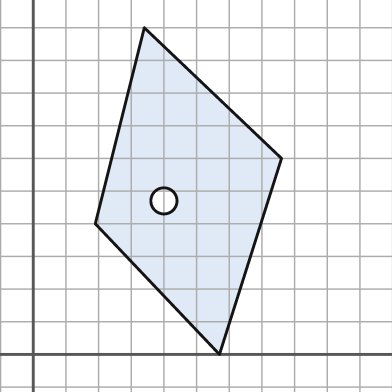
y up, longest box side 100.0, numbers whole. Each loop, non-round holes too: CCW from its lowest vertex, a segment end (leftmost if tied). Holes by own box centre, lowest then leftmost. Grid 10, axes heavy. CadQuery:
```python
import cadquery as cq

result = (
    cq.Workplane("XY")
    .moveTo(57.0, 0.0)
    .lineTo(76.0, 60.0)
    .lineTo(34.0, 100.0)
    .lineTo(19.0, 40.0)
    .close()
    .moveTo(40.0, 47.0)
    .circle(4.0)
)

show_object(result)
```